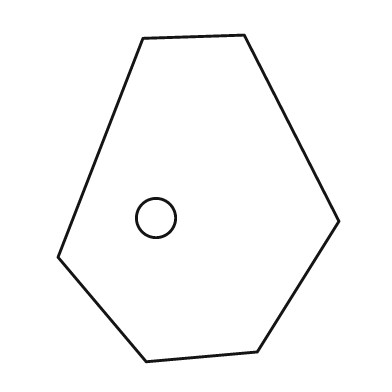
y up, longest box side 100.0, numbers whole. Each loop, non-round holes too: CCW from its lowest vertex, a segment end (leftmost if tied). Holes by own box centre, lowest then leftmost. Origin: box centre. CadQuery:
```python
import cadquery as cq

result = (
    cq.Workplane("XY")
    .moveTo(-16.0, -50.0)
    .lineTo(18.0, -47.0)
    .lineTo(43.0, -7.0)
    .lineTo(14.0, 50.0)
    .lineTo(-17.0, 49.0)
    .lineTo(-43.0, -18.0)
    .close()
    .moveTo(-13.0, -6.0)
    .circle(6.0)
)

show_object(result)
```